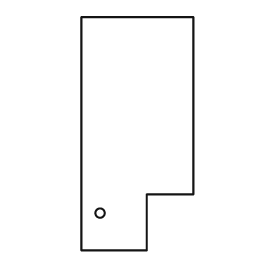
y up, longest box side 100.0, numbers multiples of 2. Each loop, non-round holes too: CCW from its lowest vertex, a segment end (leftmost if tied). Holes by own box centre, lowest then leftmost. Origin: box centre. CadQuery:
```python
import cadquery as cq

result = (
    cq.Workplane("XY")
    .moveTo(-24.0, -50.0)
    .lineTo(4.0, -50.0)
    .lineTo(4.0, -26.0)
    .lineTo(24.0, -26.0)
    .lineTo(24.0, 50.0)
    .lineTo(-24.0, 50.0)
    .close()
    .moveTo(-16.0, -34.0)
    .circle(2.0)
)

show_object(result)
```